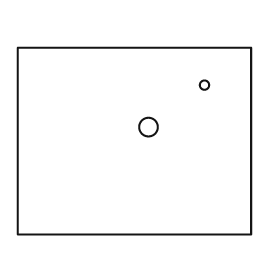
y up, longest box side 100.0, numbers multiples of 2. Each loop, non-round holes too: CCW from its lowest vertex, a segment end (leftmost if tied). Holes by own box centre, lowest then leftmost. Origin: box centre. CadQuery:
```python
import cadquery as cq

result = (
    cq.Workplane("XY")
    .moveTo(-50.0, -40.0)
    .lineTo(50.0, -40.0)
    .lineTo(50.0, 40.0)
    .lineTo(-50.0, 40.0)
    .close()
    .moveTo(6.0, 6.0)
    .circle(4.0)
    .moveTo(30.0, 24.0)
    .circle(2.0)
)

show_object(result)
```